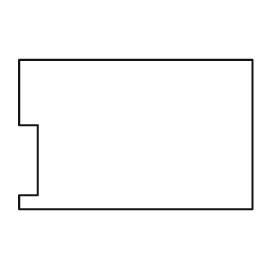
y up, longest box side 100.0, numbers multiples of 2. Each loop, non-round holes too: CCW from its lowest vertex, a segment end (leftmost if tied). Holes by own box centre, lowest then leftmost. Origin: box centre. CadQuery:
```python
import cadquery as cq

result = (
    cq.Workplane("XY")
    .moveTo(-50.0, -32.0)
    .lineTo(50.0, -32.0)
    .lineTo(50.0, 32.0)
    .lineTo(-50.0, 32.0)
    .lineTo(-50.0, 4.0)
    .lineTo(-42.0, 4.0)
    .lineTo(-42.0, -26.0)
    .lineTo(-50.0, -26.0)
    .close()
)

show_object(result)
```